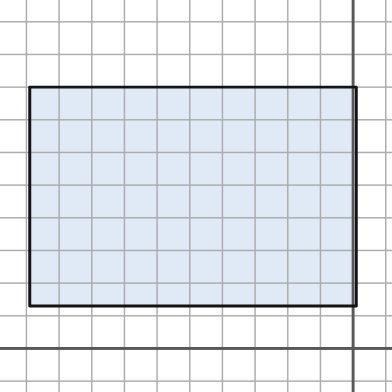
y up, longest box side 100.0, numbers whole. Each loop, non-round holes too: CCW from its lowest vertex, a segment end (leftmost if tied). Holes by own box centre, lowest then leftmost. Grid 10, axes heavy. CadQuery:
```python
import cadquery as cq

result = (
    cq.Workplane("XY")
    .moveTo(-99.0, 13.0)
    .lineTo(1.0, 13.0)
    .lineTo(1.0, 80.0)
    .lineTo(-99.0, 80.0)
    .close()
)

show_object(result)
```